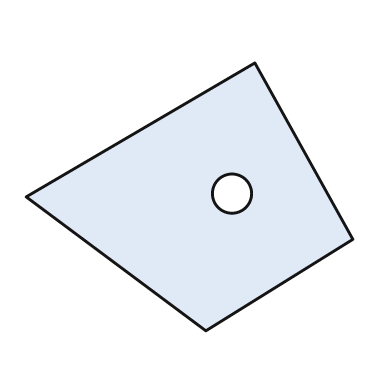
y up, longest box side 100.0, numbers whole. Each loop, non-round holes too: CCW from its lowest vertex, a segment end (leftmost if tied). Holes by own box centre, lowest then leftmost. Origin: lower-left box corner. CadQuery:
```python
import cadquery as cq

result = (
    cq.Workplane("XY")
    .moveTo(55.0, 0.0)
    .lineTo(100.0, 28.0)
    .lineTo(70.0, 82.0)
    .lineTo(0.0, 41.0)
    .close()
    .moveTo(63.0, 42.0)
    .circle(6.0)
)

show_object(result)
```